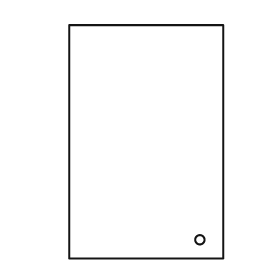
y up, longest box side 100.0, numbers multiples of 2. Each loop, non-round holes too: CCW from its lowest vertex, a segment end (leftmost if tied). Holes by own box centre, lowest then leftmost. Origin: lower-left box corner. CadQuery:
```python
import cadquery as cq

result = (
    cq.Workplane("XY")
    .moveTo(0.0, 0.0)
    .lineTo(66.0, 0.0)
    .lineTo(66.0, 100.0)
    .lineTo(0.0, 100.0)
    .close()
    .moveTo(56.0, 8.0)
    .circle(2.0)
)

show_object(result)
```